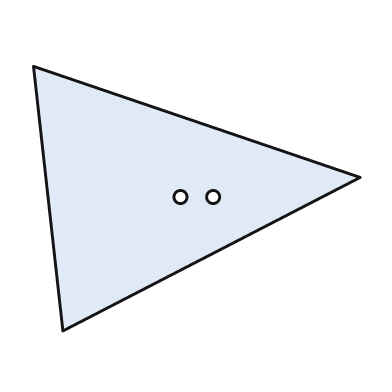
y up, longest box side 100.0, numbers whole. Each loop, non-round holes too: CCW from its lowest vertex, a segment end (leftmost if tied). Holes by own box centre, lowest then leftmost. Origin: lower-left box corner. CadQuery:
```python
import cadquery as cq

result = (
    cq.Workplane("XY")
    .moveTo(9.0, 0.0)
    .lineTo(100.0, 47.0)
    .lineTo(0.0, 81.0)
    .close()
    .moveTo(45.0, 41.0)
    .circle(2.0)
    .moveTo(55.0, 41.0)
    .circle(2.0)
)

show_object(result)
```